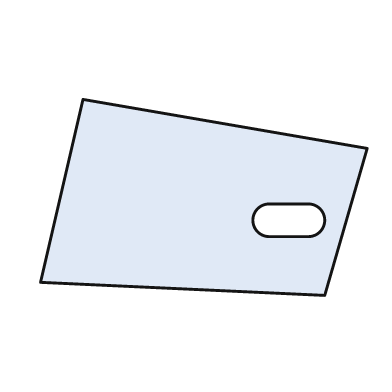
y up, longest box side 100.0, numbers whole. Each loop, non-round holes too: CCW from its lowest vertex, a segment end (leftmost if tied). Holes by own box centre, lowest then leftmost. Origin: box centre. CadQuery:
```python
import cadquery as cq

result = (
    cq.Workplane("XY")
    .moveTo(37.0, -30.0)
    .lineTo(50.0, 15.0)
    .lineTo(-37.0, 30.0)
    .lineTo(-50.0, -26.0)
    .close()
    .moveTo(20.0, -12.0)
    .lineTo(32.0, -12.0)
    .threePointArc((37.0, -7.0), (32.0, -2.0))
    .lineTo(20.0, -2.0)
    .threePointArc((15.0, -7.0), (20.0, -12.0))
    .close()
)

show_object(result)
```